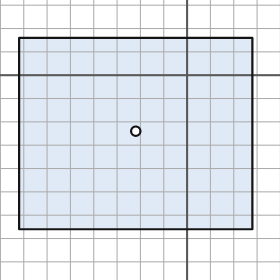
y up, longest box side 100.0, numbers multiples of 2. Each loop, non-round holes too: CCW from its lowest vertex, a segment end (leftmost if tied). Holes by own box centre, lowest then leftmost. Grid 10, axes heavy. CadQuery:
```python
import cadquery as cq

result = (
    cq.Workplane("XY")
    .moveTo(-72.0, -66.0)
    .lineTo(28.0, -66.0)
    .lineTo(28.0, 16.0)
    .lineTo(-72.0, 16.0)
    .close()
    .moveTo(-22.0, -24.0)
    .circle(2.0)
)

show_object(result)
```